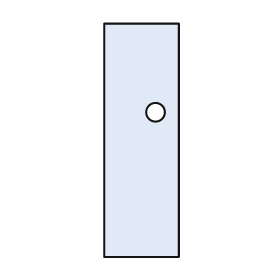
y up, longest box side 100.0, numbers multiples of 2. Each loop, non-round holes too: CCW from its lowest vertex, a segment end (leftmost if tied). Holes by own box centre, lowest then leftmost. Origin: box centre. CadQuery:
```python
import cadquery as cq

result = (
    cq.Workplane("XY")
    .moveTo(-16.0, -50.0)
    .lineTo(16.0, -50.0)
    .lineTo(16.0, 50.0)
    .lineTo(-16.0, 50.0)
    .close()
    .moveTo(6.0, 12.0)
    .circle(4.0)
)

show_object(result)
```